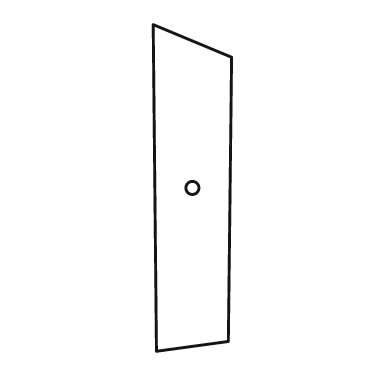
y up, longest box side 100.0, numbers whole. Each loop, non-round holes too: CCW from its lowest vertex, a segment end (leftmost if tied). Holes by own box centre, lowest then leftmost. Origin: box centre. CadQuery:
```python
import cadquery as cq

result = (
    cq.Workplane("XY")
    .moveTo(-11.0, -50.0)
    .lineTo(11.0, -47.0)
    .lineTo(12.0, 40.0)
    .lineTo(-12.0, 50.0)
    .close()
    .moveTo(0.0, 0.0)
    .circle(2.0)
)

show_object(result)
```